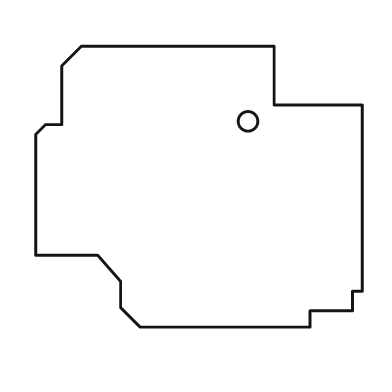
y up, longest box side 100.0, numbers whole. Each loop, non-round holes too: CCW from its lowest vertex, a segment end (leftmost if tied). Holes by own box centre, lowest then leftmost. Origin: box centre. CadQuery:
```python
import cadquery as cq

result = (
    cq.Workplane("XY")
    .moveTo(-18.0, -43.0)
    .lineTo(34.0, -43.0)
    .lineTo(34.0, -38.0)
    .lineTo(47.0, -38.0)
    .lineTo(47.0, -32.0)
    .lineTo(50.0, -32.0)
    .lineTo(50.0, 25.0)
    .lineTo(23.0, 25.0)
    .lineTo(23.0, 43.0)
    .lineTo(-36.0, 43.0)
    .lineTo(-42.0, 37.0)
    .lineTo(-42.0, 19.0)
    .lineTo(-47.0, 19.0)
    .lineTo(-50.0, 16.0)
    .lineTo(-50.0, -21.0)
    .lineTo(-31.0, -21.0)
    .lineTo(-24.0, -29.0)
    .lineTo(-24.0, -37.0)
    .close()
    .moveTo(15.0, 20.0)
    .circle(3.0)
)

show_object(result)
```